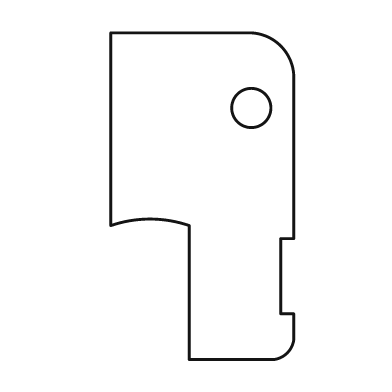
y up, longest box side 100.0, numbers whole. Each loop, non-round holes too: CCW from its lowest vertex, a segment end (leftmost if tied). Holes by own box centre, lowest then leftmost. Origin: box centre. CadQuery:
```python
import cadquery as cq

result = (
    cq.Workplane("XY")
    .moveTo(-4.0, -50.0)
    .lineTo(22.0, -50.0)
    .threePointArc((26.0, -48.0), (28.0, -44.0))
    .lineTo(28.0, -36.0)
    .lineTo(24.0, -36.0)
    .lineTo(24.0, -13.0)
    .lineTo(28.0, -13.0)
    .lineTo(28.0, 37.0)
    .threePointArc((24.0, 46.0), (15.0, 50.0))
    .lineTo(-28.0, 50.0)
    .lineTo(-28.0, -9.0)
    .threePointArc((-16.0, -7.0), (-4.0, -9.0))
    .close()
    .moveTo(15.0, 27.0)
    .circle(6.0)
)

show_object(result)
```